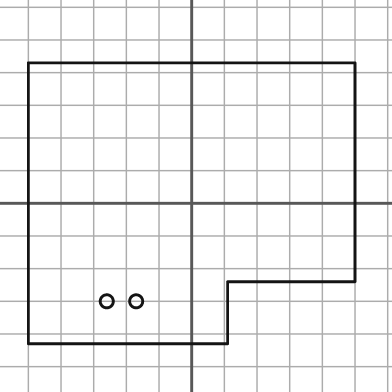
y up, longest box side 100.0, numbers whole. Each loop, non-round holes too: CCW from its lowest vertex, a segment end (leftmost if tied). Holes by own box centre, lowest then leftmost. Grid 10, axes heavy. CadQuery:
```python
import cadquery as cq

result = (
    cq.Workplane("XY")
    .moveTo(-50.0, -43.0)
    .lineTo(11.0, -43.0)
    .lineTo(11.0, -24.0)
    .lineTo(50.0, -24.0)
    .lineTo(50.0, 43.0)
    .lineTo(-50.0, 43.0)
    .close()
    .moveTo(-26.0, -30.0)
    .circle(2.0)
    .moveTo(-17.0, -30.0)
    .circle(2.0)
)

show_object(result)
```